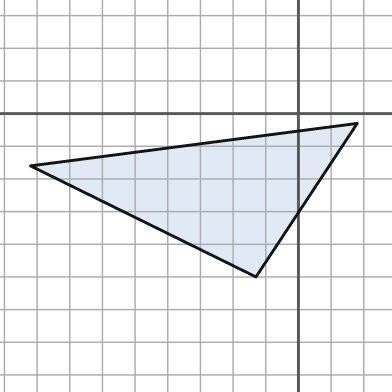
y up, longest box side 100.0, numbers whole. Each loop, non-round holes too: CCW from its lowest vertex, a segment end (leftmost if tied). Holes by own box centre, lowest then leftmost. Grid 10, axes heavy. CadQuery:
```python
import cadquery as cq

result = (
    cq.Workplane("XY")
    .moveTo(-13.0, -50.0)
    .lineTo(18.0, -3.0)
    .lineTo(-82.0, -16.0)
    .close()
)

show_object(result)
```